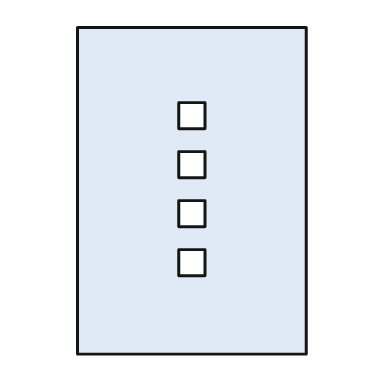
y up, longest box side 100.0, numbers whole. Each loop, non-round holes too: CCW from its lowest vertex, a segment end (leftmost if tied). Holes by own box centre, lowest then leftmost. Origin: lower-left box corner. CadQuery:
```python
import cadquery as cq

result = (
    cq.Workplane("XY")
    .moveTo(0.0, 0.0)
    .lineTo(70.0, 0.0)
    .lineTo(70.0, 100.0)
    .lineTo(0.0, 100.0)
    .close()
    .moveTo(31.0, 24.0)
    .lineTo(39.0, 24.0)
    .lineTo(39.0, 32.0)
    .lineTo(31.0, 32.0)
    .close()
    .moveTo(31.0, 39.0)
    .lineTo(39.0, 39.0)
    .lineTo(39.0, 47.0)
    .lineTo(31.0, 47.0)
    .close()
    .moveTo(31.0, 54.0)
    .lineTo(39.0, 54.0)
    .lineTo(39.0, 62.0)
    .lineTo(31.0, 62.0)
    .close()
    .moveTo(31.0, 69.0)
    .lineTo(39.0, 69.0)
    .lineTo(39.0, 77.0)
    .lineTo(31.0, 77.0)
    .close()
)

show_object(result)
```